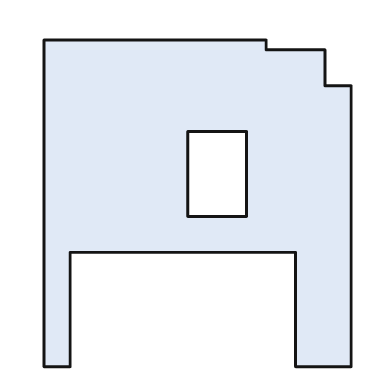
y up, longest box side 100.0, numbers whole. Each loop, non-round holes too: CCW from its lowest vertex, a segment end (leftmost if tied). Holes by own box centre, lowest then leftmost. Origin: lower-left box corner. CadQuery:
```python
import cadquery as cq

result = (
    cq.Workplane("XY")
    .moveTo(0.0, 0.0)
    .lineTo(8.0, 0.0)
    .lineTo(8.0, 35.0)
    .lineTo(77.0, 35.0)
    .lineTo(77.0, 0.0)
    .lineTo(94.0, 0.0)
    .lineTo(94.0, 86.0)
    .lineTo(86.0, 86.0)
    .lineTo(86.0, 97.0)
    .lineTo(68.0, 97.0)
    .lineTo(68.0, 100.0)
    .lineTo(0.0, 100.0)
    .close()
    .moveTo(44.0, 46.0)
    .lineTo(62.0, 46.0)
    .lineTo(62.0, 72.0)
    .lineTo(44.0, 72.0)
    .close()
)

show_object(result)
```